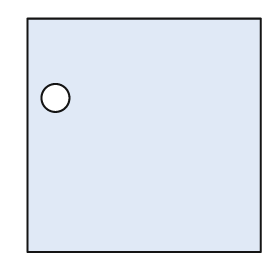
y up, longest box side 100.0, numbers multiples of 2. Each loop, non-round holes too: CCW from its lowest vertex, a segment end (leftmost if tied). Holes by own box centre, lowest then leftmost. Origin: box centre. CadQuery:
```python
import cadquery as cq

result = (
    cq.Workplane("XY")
    .moveTo(-50.0, -50.0)
    .lineTo(50.0, -50.0)
    .lineTo(50.0, 50.0)
    .lineTo(-50.0, 50.0)
    .close()
    .moveTo(-38.0, 16.0)
    .circle(6.0)
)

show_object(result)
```